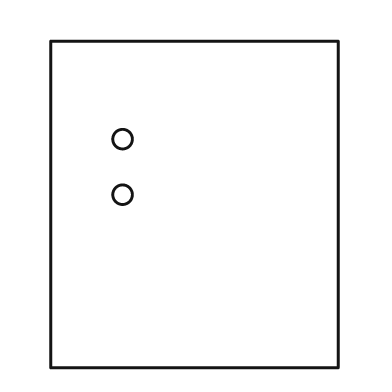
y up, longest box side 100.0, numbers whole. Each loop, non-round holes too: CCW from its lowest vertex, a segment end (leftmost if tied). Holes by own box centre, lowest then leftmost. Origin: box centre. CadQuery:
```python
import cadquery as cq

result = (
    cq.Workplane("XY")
    .moveTo(-44.0, -50.0)
    .lineTo(44.0, -50.0)
    .lineTo(44.0, 50.0)
    .lineTo(-44.0, 50.0)
    .close()
    .moveTo(-22.0, 3.0)
    .circle(3.0)
    .moveTo(-22.0, 20.0)
    .circle(3.0)
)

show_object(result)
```